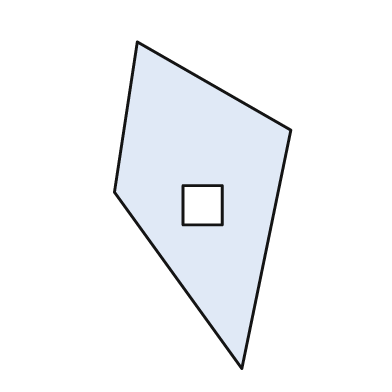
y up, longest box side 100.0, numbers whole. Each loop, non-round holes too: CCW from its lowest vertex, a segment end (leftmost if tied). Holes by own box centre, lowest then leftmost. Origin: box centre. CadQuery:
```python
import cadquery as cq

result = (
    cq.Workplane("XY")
    .moveTo(12.0, -50.0)
    .lineTo(27.0, 23.0)
    .lineTo(-20.0, 50.0)
    .lineTo(-27.0, 4.0)
    .close()
    .moveTo(-6.0, -6.0)
    .lineTo(6.0, -6.0)
    .lineTo(6.0, 6.0)
    .lineTo(-6.0, 6.0)
    .close()
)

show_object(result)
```